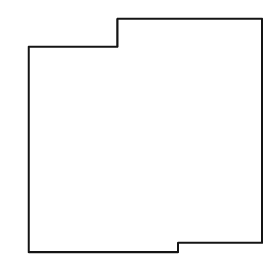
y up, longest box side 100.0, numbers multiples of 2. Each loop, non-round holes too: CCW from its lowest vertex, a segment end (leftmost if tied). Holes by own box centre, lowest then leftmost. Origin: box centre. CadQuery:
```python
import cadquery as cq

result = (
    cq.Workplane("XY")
    .moveTo(-50.0, -50.0)
    .lineTo(14.0, -50.0)
    .lineTo(14.0, -46.0)
    .lineTo(50.0, -46.0)
    .lineTo(50.0, 50.0)
    .lineTo(-12.0, 50.0)
    .lineTo(-12.0, 38.0)
    .lineTo(-50.0, 38.0)
    .close()
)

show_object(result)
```